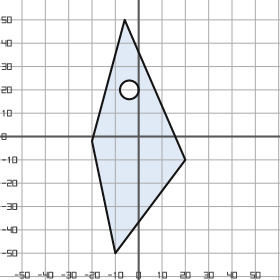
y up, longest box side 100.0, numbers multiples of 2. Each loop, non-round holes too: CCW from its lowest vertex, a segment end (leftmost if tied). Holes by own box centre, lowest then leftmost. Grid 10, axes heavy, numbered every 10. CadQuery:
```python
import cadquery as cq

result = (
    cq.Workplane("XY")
    .moveTo(-10.0, -50.0)
    .lineTo(20.0, -10.0)
    .lineTo(-6.0, 50.0)
    .lineTo(-20.0, -2.0)
    .close()
    .moveTo(-4.0, 20.0)
    .circle(4.0)
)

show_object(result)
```